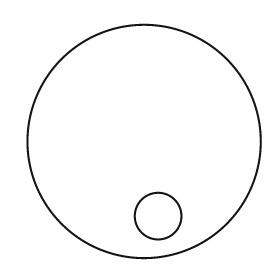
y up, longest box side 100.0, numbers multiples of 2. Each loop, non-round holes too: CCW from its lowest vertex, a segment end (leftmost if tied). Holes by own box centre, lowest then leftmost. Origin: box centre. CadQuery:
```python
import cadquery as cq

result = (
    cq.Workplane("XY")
    .moveTo(0.0, 0.0)
    .circle(50.0)
    .moveTo(6.0, -32.0)
    .circle(10.0)
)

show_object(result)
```